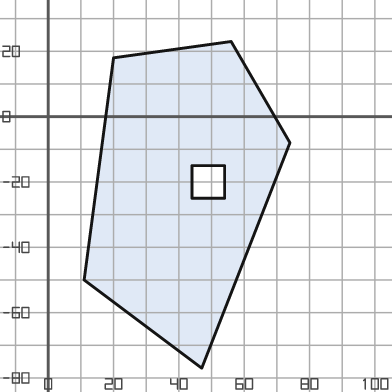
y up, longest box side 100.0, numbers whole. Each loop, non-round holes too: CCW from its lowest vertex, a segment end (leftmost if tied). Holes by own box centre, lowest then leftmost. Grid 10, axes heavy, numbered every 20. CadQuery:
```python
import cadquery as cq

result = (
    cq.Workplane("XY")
    .moveTo(47.0, -77.0)
    .lineTo(74.0, -8.0)
    .lineTo(56.0, 23.0)
    .lineTo(20.0, 18.0)
    .lineTo(11.0, -50.0)
    .close()
    .moveTo(44.0, -25.0)
    .lineTo(54.0, -25.0)
    .lineTo(54.0, -15.0)
    .lineTo(44.0, -15.0)
    .close()
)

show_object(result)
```